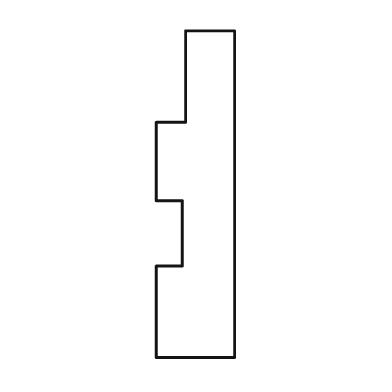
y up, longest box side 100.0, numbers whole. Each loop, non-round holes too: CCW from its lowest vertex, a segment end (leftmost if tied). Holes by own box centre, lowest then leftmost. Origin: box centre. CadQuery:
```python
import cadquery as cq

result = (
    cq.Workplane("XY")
    .moveTo(-12.0, -50.0)
    .lineTo(12.0, -50.0)
    .lineTo(12.0, 50.0)
    .lineTo(-3.0, 50.0)
    .lineTo(-3.0, 22.0)
    .lineTo(-12.0, 22.0)
    .lineTo(-12.0, -2.0)
    .lineTo(-4.0, -2.0)
    .lineTo(-4.0, -22.0)
    .lineTo(-12.0, -22.0)
    .close()
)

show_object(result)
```